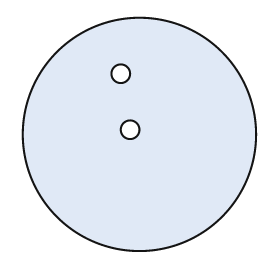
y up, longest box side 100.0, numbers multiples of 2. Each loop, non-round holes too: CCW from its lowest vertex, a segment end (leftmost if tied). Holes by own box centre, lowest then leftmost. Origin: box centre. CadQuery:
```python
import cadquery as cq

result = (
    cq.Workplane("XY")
    .moveTo(0.0, 0.0)
    .circle(50.0)
    .moveTo(-4.0, 2.0)
    .circle(4.0)
    .moveTo(-8.0, 26.0)
    .circle(4.0)
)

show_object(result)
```